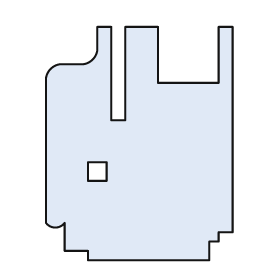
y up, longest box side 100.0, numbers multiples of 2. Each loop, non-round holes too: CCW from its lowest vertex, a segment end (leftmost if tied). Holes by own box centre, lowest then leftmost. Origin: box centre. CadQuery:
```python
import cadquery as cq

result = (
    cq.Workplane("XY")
    .moveTo(-22.0, -50.0)
    .lineTo(30.0, -50.0)
    .lineTo(30.0, -42.0)
    .lineTo(34.0, -42.0)
    .lineTo(34.0, -38.0)
    .lineTo(40.0, -38.0)
    .lineTo(40.0, 50.0)
    .lineTo(34.0, 50.0)
    .lineTo(34.0, 26.0)
    .lineTo(8.0, 26.0)
    .lineTo(8.0, 50.0)
    .lineTo(-6.0, 50.0)
    .lineTo(-6.0, 10.0)
    .lineTo(-12.0, 10.0)
    .lineTo(-12.0, 50.0)
    .lineTo(-18.0, 50.0)
    .lineTo(-18.0, 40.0)
    .threePointArc((-20.0, 36.0), (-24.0, 34.0))
    .lineTo(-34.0, 34.0)
    .threePointArc((-38.0, 32.0), (-40.0, 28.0))
    .lineTo(-40.0, -34.0)
    .threePointArc((-36.0, -36.0), (-32.0, -34.0))
    .lineTo(-32.0, -46.0)
    .lineTo(-22.0, -46.0)
    .close()
    .moveTo(-22.0, -16.0)
    .lineTo(-14.0, -16.0)
    .lineTo(-14.0, -8.0)
    .lineTo(-22.0, -8.0)
    .close()
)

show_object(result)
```